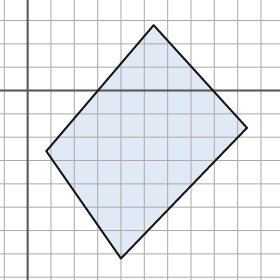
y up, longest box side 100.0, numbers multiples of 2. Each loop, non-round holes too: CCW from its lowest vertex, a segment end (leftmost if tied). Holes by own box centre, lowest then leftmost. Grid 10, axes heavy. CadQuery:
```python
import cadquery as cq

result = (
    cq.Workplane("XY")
    .moveTo(40.0, -72.0)
    .lineTo(94.0, -16.0)
    .lineTo(54.0, 28.0)
    .lineTo(8.0, -26.0)
    .close()
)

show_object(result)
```